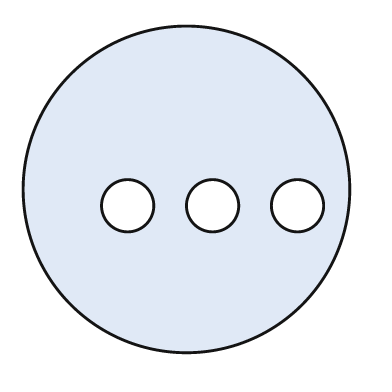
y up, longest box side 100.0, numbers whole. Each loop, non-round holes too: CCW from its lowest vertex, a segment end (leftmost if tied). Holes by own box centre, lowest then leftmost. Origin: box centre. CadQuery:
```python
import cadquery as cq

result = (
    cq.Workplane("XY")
    .moveTo(0.0, 0.0)
    .circle(50.0)
    .moveTo(-18.0, -5.0)
    .circle(8.0)
    .moveTo(8.0, -5.0)
    .circle(8.0)
    .moveTo(34.0, -5.0)
    .circle(8.0)
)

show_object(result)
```